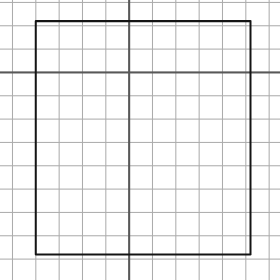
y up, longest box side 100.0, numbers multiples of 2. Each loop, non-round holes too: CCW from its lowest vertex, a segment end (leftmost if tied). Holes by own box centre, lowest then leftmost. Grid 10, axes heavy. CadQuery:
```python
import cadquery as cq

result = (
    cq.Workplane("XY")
    .moveTo(-40.0, -78.0)
    .lineTo(52.0, -78.0)
    .lineTo(52.0, 22.0)
    .lineTo(-40.0, 22.0)
    .close()
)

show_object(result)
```